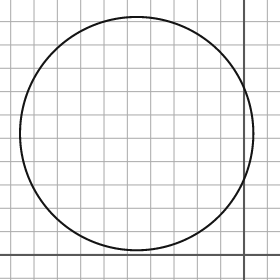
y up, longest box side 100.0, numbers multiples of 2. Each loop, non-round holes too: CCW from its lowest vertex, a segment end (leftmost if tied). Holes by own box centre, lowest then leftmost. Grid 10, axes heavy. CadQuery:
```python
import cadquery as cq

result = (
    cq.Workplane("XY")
    .moveTo(-46.0, 52.0)
    .circle(50.0)
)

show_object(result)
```